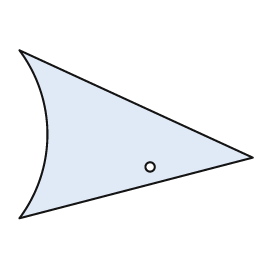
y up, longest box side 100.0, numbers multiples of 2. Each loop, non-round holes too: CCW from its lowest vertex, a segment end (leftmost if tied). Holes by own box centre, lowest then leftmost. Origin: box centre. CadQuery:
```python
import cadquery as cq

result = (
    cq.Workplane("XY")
    .moveTo(-50.0, -36.0)
    .lineTo(50.0, -10.0)
    .lineTo(-50.0, 36.0)
    .threePointArc((-38.0, 0.0), (-50.0, -36.0))
    .close()
    .moveTo(6.0, -14.0)
    .circle(2.0)
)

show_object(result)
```